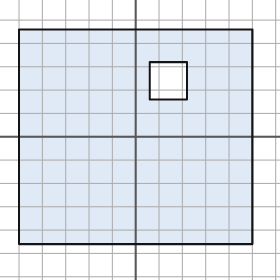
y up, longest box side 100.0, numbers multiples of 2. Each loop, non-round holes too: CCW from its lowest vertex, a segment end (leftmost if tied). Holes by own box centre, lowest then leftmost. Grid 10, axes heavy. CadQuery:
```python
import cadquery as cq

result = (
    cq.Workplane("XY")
    .moveTo(-50.0, -46.0)
    .lineTo(50.0, -46.0)
    .lineTo(50.0, 46.0)
    .lineTo(-50.0, 46.0)
    .close()
    .moveTo(6.0, 16.0)
    .lineTo(22.0, 16.0)
    .lineTo(22.0, 32.0)
    .lineTo(6.0, 32.0)
    .close()
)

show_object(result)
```